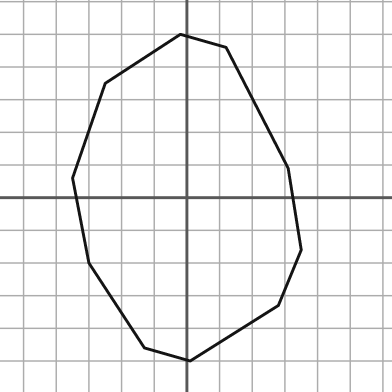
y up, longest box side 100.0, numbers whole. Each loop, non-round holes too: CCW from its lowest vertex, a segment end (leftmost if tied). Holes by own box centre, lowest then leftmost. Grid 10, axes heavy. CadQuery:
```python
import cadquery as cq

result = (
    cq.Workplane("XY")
    .moveTo(1.0, -50.0)
    .lineTo(28.0, -33.0)
    .lineTo(35.0, -16.0)
    .lineTo(31.0, 9.0)
    .lineTo(12.0, 46.0)
    .lineTo(-2.0, 50.0)
    .lineTo(-25.0, 35.0)
    .lineTo(-35.0, 6.0)
    .lineTo(-30.0, -20.0)
    .lineTo(-13.0, -46.0)
    .close()
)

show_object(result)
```